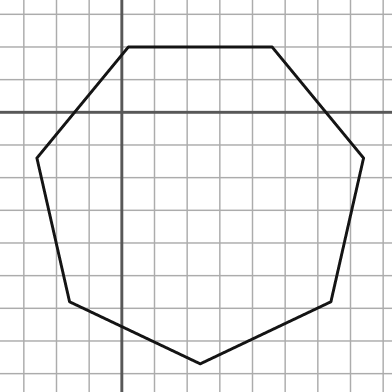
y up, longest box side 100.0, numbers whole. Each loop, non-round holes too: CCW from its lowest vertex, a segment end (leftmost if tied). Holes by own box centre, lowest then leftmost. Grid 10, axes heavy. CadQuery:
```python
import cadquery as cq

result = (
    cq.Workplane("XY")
    .moveTo(24.0, -77.0)
    .lineTo(64.0, -58.0)
    .lineTo(74.0, -14.0)
    .lineTo(46.0, 20.0)
    .lineTo(2.0, 20.0)
    .lineTo(-26.0, -14.0)
    .lineTo(-16.0, -58.0)
    .close()
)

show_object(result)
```